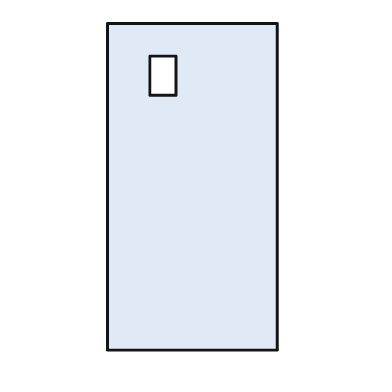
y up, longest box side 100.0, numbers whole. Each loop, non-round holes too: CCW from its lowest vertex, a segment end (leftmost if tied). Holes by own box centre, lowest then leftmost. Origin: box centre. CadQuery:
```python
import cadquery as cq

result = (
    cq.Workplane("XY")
    .moveTo(-26.0, -50.0)
    .lineTo(26.0, -50.0)
    .lineTo(26.0, 50.0)
    .lineTo(-26.0, 50.0)
    .close()
    .moveTo(-13.0, 28.0)
    .lineTo(-5.0, 28.0)
    .lineTo(-5.0, 40.0)
    .lineTo(-13.0, 40.0)
    .close()
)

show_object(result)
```